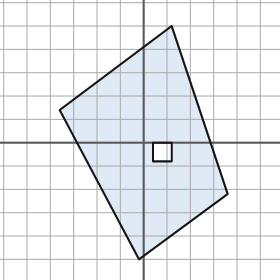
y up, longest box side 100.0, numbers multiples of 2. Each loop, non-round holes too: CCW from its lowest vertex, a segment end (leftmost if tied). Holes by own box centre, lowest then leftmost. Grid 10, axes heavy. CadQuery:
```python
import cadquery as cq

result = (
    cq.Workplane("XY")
    .moveTo(-2.0, -50.0)
    .lineTo(36.0, -22.0)
    .lineTo(12.0, 50.0)
    .lineTo(-36.0, 14.0)
    .close()
    .moveTo(4.0, -8.0)
    .lineTo(12.0, -8.0)
    .lineTo(12.0, 0.0)
    .lineTo(4.0, 0.0)
    .close()
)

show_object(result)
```